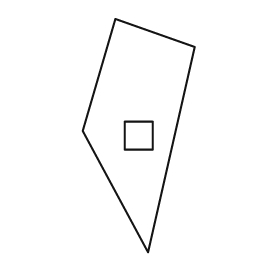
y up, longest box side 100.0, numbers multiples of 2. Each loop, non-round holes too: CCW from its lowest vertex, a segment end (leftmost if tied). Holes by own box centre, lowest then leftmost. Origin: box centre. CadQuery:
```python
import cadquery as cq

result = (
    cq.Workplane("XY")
    .moveTo(4.0, -50.0)
    .lineTo(24.0, 38.0)
    .lineTo(-10.0, 50.0)
    .lineTo(-24.0, 2.0)
    .close()
    .moveTo(-6.0, -6.0)
    .lineTo(6.0, -6.0)
    .lineTo(6.0, 6.0)
    .lineTo(-6.0, 6.0)
    .close()
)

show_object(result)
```